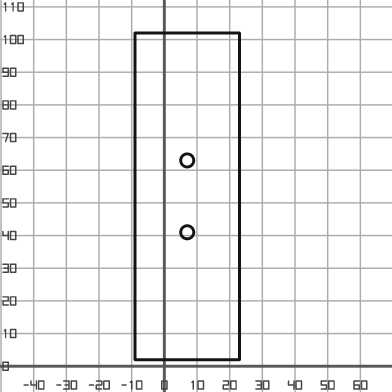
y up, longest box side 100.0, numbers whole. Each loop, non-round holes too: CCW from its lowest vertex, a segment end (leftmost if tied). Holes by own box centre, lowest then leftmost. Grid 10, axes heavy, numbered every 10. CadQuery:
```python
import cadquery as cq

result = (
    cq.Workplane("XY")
    .moveTo(-9.0, 2.0)
    .lineTo(23.0, 2.0)
    .lineTo(23.0, 102.0)
    .lineTo(-9.0, 102.0)
    .close()
    .moveTo(7.0, 41.0)
    .circle(2.0)
    .moveTo(7.0, 63.0)
    .circle(2.0)
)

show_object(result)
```